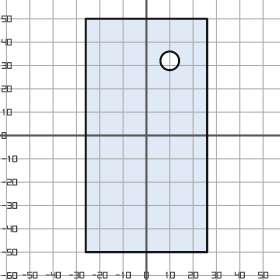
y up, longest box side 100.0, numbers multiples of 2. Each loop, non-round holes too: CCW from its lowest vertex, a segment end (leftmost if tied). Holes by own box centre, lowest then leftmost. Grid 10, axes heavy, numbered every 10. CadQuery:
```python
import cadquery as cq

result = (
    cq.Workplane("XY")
    .moveTo(-26.0, -50.0)
    .lineTo(26.0, -50.0)
    .lineTo(26.0, 50.0)
    .lineTo(-26.0, 50.0)
    .close()
    .moveTo(10.0, 32.0)
    .circle(4.0)
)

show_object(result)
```